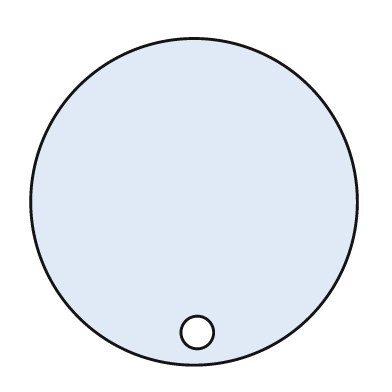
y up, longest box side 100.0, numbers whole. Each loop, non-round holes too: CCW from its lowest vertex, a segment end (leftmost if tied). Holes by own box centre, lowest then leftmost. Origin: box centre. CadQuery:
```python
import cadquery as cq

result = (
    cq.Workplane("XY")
    .moveTo(0.0, 0.0)
    .circle(50.0)
    .moveTo(1.0, -40.0)
    .circle(5.0)
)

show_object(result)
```